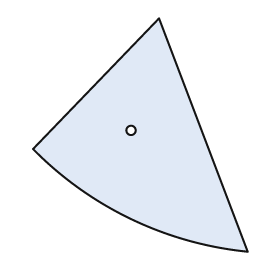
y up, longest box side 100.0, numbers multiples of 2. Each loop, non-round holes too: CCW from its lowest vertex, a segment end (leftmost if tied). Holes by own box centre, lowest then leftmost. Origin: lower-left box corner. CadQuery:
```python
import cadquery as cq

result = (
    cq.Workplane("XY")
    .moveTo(92.0, 0.0)
    .lineTo(54.0, 100.0)
    .lineTo(0.0, 44.0)
    .threePointArc((42.0, 14.0), (92.0, 0.0))
    .close()
    .moveTo(42.0, 52.0)
    .circle(2.0)
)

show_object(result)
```